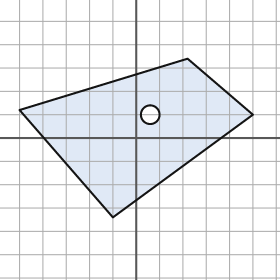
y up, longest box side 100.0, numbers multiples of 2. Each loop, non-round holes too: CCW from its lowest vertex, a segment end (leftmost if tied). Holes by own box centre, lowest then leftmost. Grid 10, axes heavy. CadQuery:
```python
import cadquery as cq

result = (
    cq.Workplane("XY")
    .moveTo(-10.0, -34.0)
    .lineTo(50.0, 10.0)
    .lineTo(22.0, 34.0)
    .lineTo(-50.0, 12.0)
    .close()
    .moveTo(6.0, 10.0)
    .circle(4.0)
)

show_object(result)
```